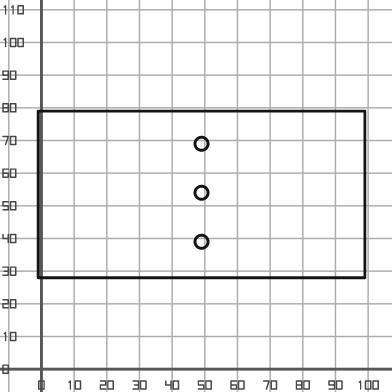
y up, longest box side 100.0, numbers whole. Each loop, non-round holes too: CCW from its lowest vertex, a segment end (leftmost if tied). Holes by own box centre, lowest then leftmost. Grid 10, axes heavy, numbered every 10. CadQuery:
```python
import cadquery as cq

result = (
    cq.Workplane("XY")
    .moveTo(-1.0, 28.0)
    .lineTo(99.0, 28.0)
    .lineTo(99.0, 79.0)
    .lineTo(-1.0, 79.0)
    .close()
    .moveTo(49.0, 39.0)
    .circle(2.0)
    .moveTo(49.0, 54.0)
    .circle(2.0)
    .moveTo(49.0, 69.0)
    .circle(2.0)
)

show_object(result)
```